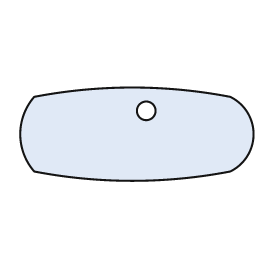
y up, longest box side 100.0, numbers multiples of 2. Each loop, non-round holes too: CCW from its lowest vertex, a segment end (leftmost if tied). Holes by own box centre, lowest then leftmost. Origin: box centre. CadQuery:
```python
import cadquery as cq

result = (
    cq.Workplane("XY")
    .moveTo(-44.0, -16.0)
    .threePointArc((-2.0, -20.0), (40.0, -16.0))
    .threePointArc((50.0, 0.0), (40.0, 16.0))
    .threePointArc((-2.0, 20.0), (-44.0, 16.0))
    .threePointArc((-50.0, 0.0), (-44.0, -16.0))
    .close()
    .moveTo(4.0, 10.0)
    .circle(4.0)
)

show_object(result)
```